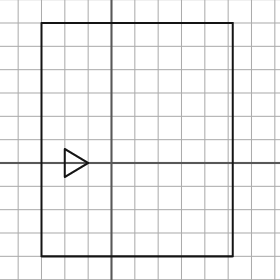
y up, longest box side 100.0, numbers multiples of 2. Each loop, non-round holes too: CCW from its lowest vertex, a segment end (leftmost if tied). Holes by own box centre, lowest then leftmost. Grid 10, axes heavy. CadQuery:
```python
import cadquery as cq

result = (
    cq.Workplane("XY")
    .moveTo(-30.0, -40.0)
    .lineTo(52.0, -40.0)
    .lineTo(52.0, 60.0)
    .lineTo(-30.0, 60.0)
    .close()
    .moveTo(-20.0, -6.0)
    .lineTo(-10.0, 0.0)
    .lineTo(-20.0, 6.0)
    .close()
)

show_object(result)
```